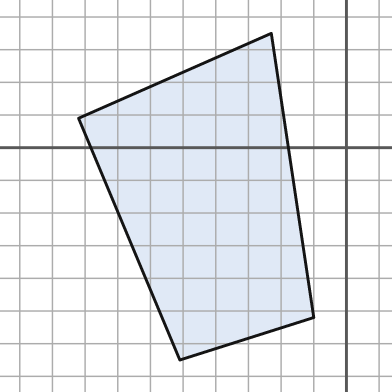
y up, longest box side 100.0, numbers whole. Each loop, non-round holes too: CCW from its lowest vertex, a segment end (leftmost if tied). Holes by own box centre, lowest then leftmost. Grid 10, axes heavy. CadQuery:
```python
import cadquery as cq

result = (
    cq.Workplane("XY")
    .moveTo(-51.0, -65.0)
    .lineTo(-10.0, -52.0)
    .lineTo(-23.0, 35.0)
    .lineTo(-82.0, 9.0)
    .close()
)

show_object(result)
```